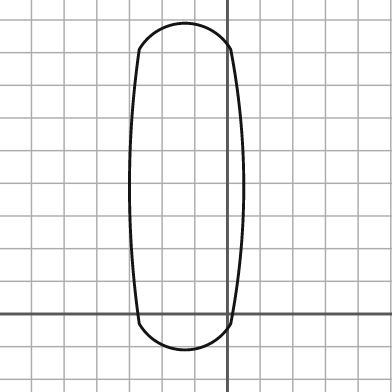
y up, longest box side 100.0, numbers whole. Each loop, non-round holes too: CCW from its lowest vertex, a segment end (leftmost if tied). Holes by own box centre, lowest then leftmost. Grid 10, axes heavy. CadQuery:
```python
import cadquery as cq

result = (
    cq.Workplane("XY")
    .moveTo(-27.0, -3.0)
    .threePointArc((-13.0, -11.0), (1.0, -3.0))
    .threePointArc((5.0, 39.0), (1.0, 81.0))
    .threePointArc((-13.0, 89.0), (-27.0, 81.0))
    .threePointArc((-30.0, 39.0), (-27.0, -3.0))
    .close()
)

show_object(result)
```